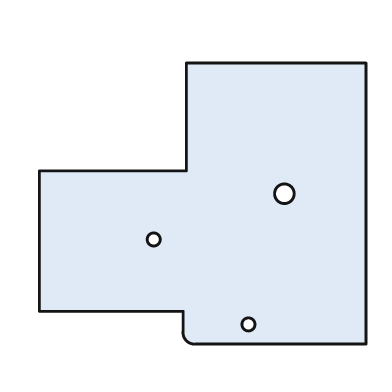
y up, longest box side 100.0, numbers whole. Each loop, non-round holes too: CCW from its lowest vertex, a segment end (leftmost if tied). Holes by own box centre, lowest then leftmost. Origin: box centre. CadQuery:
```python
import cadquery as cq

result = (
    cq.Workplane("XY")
    .moveTo(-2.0, -43.0)
    .lineTo(50.0, -43.0)
    .lineTo(50.0, 43.0)
    .lineTo(-5.0, 43.0)
    .lineTo(-5.0, 10.0)
    .lineTo(-50.0, 10.0)
    .lineTo(-50.0, -33.0)
    .lineTo(-6.0, -33.0)
    .lineTo(-6.0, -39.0)
    .threePointArc((-5.0, -42.0), (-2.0, -43.0))
    .close()
    .moveTo(14.0, -37.0)
    .circle(2.0)
    .moveTo(-15.0, -11.0)
    .circle(2.0)
    .moveTo(25.0, 3.0)
    .circle(3.0)
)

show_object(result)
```